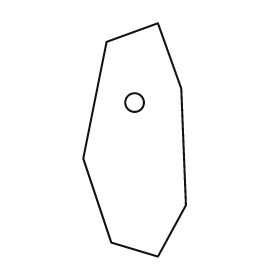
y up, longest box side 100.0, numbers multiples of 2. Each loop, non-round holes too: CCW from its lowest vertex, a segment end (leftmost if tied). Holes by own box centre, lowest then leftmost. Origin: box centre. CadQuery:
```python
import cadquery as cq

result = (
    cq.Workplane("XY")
    .moveTo(10.0, -50.0)
    .lineTo(22.0, -28.0)
    .lineTo(20.0, 22.0)
    .lineTo(10.0, 50.0)
    .lineTo(-12.0, 42.0)
    .lineTo(-22.0, -8.0)
    .lineTo(-10.0, -44.0)
    .close()
    .moveTo(0.0, 16.0)
    .circle(4.0)
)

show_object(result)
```